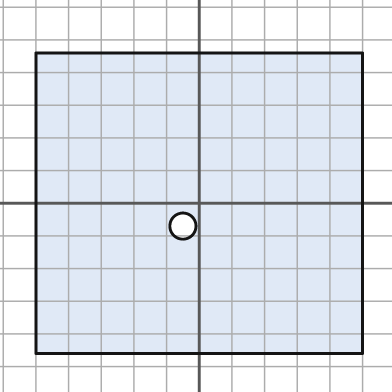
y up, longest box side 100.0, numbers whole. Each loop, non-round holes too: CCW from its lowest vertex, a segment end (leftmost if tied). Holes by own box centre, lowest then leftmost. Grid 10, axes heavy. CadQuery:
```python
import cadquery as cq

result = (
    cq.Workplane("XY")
    .moveTo(-50.0, -46.0)
    .lineTo(50.0, -46.0)
    .lineTo(50.0, 46.0)
    .lineTo(-50.0, 46.0)
    .close()
    .moveTo(-5.0, -7.0)
    .circle(4.0)
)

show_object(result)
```